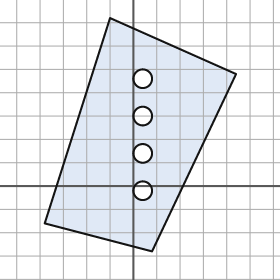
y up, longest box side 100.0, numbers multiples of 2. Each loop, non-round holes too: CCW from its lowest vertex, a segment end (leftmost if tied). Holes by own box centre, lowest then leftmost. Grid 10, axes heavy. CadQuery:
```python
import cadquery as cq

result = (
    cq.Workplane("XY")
    .moveTo(8.0, -28.0)
    .lineTo(44.0, 48.0)
    .lineTo(-10.0, 72.0)
    .lineTo(-38.0, -16.0)
    .close()
    .moveTo(4.0, -2.0)
    .circle(4.0)
    .moveTo(4.0, 14.0)
    .circle(4.0)
    .moveTo(4.0, 30.0)
    .circle(4.0)
    .moveTo(4.0, 46.0)
    .circle(4.0)
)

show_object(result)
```